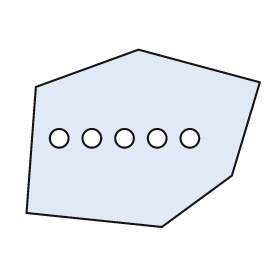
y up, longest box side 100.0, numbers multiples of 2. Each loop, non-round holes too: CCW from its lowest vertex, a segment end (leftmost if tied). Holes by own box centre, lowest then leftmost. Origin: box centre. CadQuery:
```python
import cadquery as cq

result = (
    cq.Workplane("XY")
    .moveTo(8.0, -38.0)
    .lineTo(38.0, -16.0)
    .lineTo(50.0, 24.0)
    .lineTo(-2.0, 38.0)
    .lineTo(-46.0, 22.0)
    .lineTo(-50.0, -32.0)
    .close()
    .moveTo(-36.0, 0.0)
    .circle(4.0)
    .moveTo(-22.0, 0.0)
    .circle(4.0)
    .moveTo(-8.0, 0.0)
    .circle(4.0)
    .moveTo(6.0, 0.0)
    .circle(4.0)
    .moveTo(20.0, 0.0)
    .circle(4.0)
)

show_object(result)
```